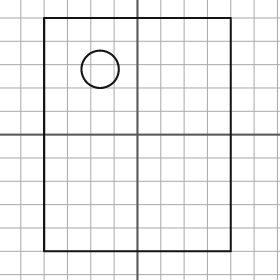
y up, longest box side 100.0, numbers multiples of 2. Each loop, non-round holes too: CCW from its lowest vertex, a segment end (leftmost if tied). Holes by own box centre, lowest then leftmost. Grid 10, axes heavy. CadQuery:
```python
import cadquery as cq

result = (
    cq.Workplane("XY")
    .moveTo(-40.0, -50.0)
    .lineTo(40.0, -50.0)
    .lineTo(40.0, 50.0)
    .lineTo(-40.0, 50.0)
    .close()
    .moveTo(-16.0, 28.0)
    .circle(8.0)
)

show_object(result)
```